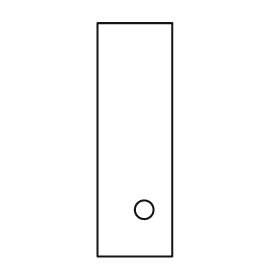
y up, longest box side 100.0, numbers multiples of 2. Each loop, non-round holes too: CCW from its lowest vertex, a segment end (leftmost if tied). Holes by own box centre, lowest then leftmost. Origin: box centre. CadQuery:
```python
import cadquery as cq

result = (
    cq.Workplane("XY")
    .moveTo(-16.0, -50.0)
    .lineTo(16.0, -50.0)
    .lineTo(16.0, 50.0)
    .lineTo(-16.0, 50.0)
    .close()
    .moveTo(4.0, -30.0)
    .circle(4.0)
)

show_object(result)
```